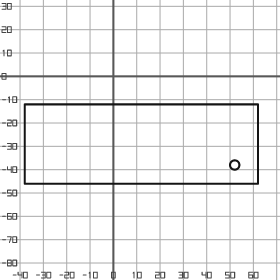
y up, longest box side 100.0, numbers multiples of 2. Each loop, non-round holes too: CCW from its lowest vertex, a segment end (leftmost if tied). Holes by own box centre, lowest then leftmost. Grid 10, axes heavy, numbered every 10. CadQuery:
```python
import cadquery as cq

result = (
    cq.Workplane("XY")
    .moveTo(-38.0, -46.0)
    .lineTo(62.0, -46.0)
    .lineTo(62.0, -12.0)
    .lineTo(-38.0, -12.0)
    .close()
    .moveTo(52.0, -38.0)
    .circle(2.0)
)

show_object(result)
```